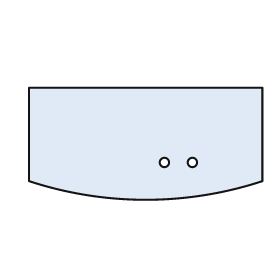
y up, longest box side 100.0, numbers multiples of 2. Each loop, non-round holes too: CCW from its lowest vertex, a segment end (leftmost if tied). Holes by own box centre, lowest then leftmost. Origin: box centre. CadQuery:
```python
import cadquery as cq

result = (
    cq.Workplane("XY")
    .moveTo(-50.0, -16.0)
    .threePointArc((0.0, -24.0), (50.0, -16.0))
    .lineTo(50.0, 24.0)
    .lineTo(-50.0, 24.0)
    .close()
    .moveTo(8.0, -8.0)
    .circle(2.0)
    .moveTo(20.0, -8.0)
    .circle(2.0)
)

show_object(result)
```